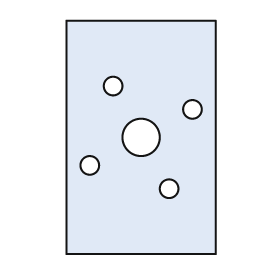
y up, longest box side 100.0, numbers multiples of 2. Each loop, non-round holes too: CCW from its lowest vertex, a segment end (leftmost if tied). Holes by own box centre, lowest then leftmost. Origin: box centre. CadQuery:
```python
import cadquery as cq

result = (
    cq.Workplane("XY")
    .moveTo(-32.0, -50.0)
    .lineTo(32.0, -50.0)
    .lineTo(32.0, 50.0)
    .lineTo(-32.0, 50.0)
    .close()
    .moveTo(12.0, -22.0)
    .circle(4.0)
    .moveTo(-22.0, -12.0)
    .circle(4.0)
    .moveTo(0.0, 0.0)
    .circle(8.0)
    .moveTo(22.0, 12.0)
    .circle(4.0)
    .moveTo(-12.0, 22.0)
    .circle(4.0)
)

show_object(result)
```